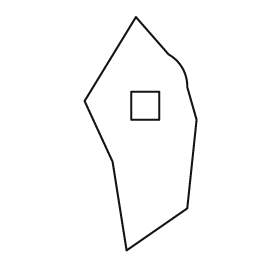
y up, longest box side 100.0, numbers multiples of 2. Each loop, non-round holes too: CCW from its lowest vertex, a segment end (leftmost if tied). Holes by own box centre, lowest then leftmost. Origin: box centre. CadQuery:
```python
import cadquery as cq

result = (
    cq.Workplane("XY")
    .moveTo(-6.0, -50.0)
    .lineTo(20.0, -32.0)
    .lineTo(24.0, 6.0)
    .lineTo(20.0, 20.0)
    .threePointArc((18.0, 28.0), (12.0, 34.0))
    .lineTo(-2.0, 50.0)
    .lineTo(-24.0, 14.0)
    .lineTo(-12.0, -12.0)
    .close()
    .moveTo(-4.0, 6.0)
    .lineTo(8.0, 6.0)
    .lineTo(8.0, 18.0)
    .lineTo(-4.0, 18.0)
    .close()
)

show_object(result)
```